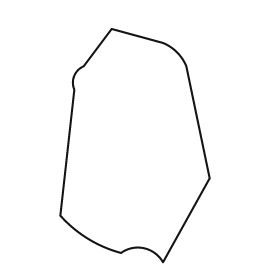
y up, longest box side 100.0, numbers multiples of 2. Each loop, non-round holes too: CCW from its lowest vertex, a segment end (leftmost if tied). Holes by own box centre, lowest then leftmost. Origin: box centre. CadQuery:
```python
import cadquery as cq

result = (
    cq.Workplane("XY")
    .moveTo(12.0, -50.0)
    .lineTo(32.0, -14.0)
    .lineTo(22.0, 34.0)
    .threePointArc((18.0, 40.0), (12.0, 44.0))
    .lineTo(-10.0, 50.0)
    .lineTo(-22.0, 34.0)
    .threePointArc((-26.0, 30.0), (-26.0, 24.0))
    .lineTo(-32.0, -30.0)
    .threePointArc((-20.0, -40.0), (-6.0, -46.0))
    .threePointArc((4.0, -44.0), (12.0, -50.0))
    .close()
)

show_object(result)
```